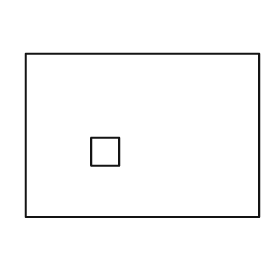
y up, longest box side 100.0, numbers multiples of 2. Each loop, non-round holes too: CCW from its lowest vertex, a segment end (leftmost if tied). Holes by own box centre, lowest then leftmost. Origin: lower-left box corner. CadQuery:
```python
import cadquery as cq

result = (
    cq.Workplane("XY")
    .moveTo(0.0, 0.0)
    .lineTo(100.0, 0.0)
    .lineTo(100.0, 70.0)
    .lineTo(0.0, 70.0)
    .close()
    .moveTo(28.0, 22.0)
    .lineTo(40.0, 22.0)
    .lineTo(40.0, 34.0)
    .lineTo(28.0, 34.0)
    .close()
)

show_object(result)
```